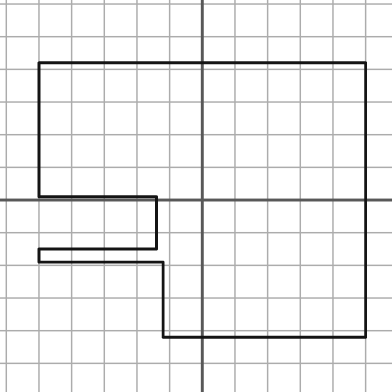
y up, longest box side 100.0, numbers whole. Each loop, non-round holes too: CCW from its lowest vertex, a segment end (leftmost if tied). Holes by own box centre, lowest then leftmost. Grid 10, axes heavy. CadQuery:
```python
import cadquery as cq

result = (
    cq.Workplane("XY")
    .moveTo(-12.0, -42.0)
    .lineTo(50.0, -42.0)
    .lineTo(50.0, 42.0)
    .lineTo(-50.0, 42.0)
    .lineTo(-50.0, 1.0)
    .lineTo(-14.0, 1.0)
    .lineTo(-14.0, -15.0)
    .lineTo(-50.0, -15.0)
    .lineTo(-50.0, -19.0)
    .lineTo(-12.0, -19.0)
    .close()
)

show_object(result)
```